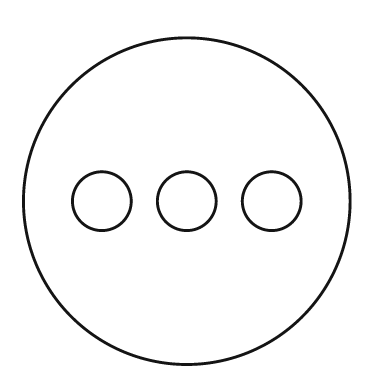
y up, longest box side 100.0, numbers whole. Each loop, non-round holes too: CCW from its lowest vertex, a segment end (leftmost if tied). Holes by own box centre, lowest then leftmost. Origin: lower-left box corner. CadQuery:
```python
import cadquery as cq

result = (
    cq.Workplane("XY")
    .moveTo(50.0, 50.0)
    .circle(50.0)
    .moveTo(24.0, 50.0)
    .circle(9.0)
    .moveTo(50.0, 50.0)
    .circle(9.0)
    .moveTo(76.0, 50.0)
    .circle(9.0)
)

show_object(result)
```